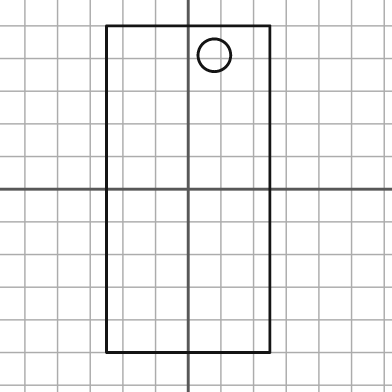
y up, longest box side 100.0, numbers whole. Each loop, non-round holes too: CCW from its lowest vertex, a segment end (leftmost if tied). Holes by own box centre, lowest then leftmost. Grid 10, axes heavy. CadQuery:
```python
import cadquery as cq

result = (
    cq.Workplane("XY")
    .moveTo(-25.0, -50.0)
    .lineTo(25.0, -50.0)
    .lineTo(25.0, 50.0)
    .lineTo(-25.0, 50.0)
    .close()
    .moveTo(8.0, 41.0)
    .circle(5.0)
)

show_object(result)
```